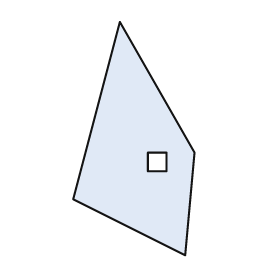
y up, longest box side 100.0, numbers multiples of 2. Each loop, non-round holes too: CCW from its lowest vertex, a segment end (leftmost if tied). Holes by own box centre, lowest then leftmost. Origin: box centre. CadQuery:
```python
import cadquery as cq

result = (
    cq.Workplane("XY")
    .moveTo(22.0, -50.0)
    .lineTo(26.0, -6.0)
    .lineTo(-6.0, 50.0)
    .lineTo(-26.0, -26.0)
    .close()
    .moveTo(6.0, -14.0)
    .lineTo(14.0, -14.0)
    .lineTo(14.0, -6.0)
    .lineTo(6.0, -6.0)
    .close()
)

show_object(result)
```